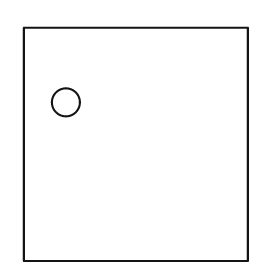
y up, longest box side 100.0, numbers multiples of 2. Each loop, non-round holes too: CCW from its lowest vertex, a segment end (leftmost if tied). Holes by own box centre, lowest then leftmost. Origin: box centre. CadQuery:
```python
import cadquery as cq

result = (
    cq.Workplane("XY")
    .moveTo(-48.0, -50.0)
    .lineTo(48.0, -50.0)
    .lineTo(48.0, 50.0)
    .lineTo(-48.0, 50.0)
    .close()
    .moveTo(-30.0, 18.0)
    .circle(6.0)
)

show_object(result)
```